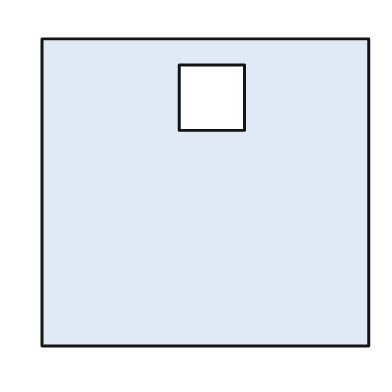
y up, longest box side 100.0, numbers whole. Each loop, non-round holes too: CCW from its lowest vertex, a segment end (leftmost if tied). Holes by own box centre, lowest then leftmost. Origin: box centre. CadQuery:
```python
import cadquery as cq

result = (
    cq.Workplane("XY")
    .moveTo(-50.0, -47.0)
    .lineTo(50.0, -47.0)
    .lineTo(50.0, 47.0)
    .lineTo(-50.0, 47.0)
    .close()
    .moveTo(-8.0, 19.0)
    .lineTo(12.0, 19.0)
    .lineTo(12.0, 39.0)
    .lineTo(-8.0, 39.0)
    .close()
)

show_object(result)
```